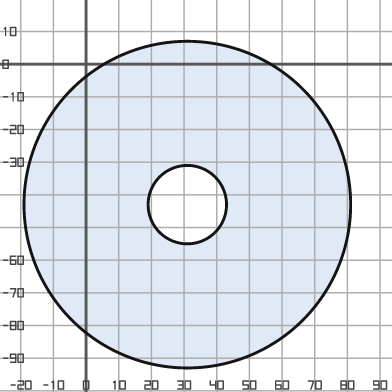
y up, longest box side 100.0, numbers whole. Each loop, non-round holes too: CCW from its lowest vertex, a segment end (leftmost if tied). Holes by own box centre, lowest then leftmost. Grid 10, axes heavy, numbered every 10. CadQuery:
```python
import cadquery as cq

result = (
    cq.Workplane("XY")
    .moveTo(31.0, -43.0)
    .circle(50.0)
    .moveTo(31.0, -43.0)
    .circle(12.0)
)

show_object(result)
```